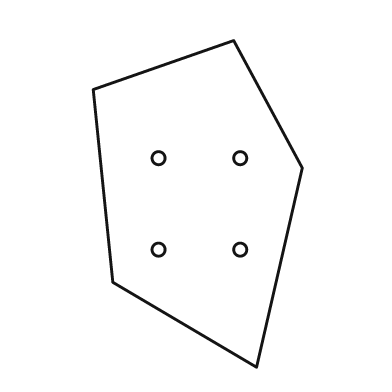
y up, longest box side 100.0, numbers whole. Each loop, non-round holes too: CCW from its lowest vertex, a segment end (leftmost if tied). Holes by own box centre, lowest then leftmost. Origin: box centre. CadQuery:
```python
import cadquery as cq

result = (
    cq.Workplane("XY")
    .moveTo(18.0, -50.0)
    .lineTo(32.0, 11.0)
    .lineTo(11.0, 50.0)
    .lineTo(-32.0, 35.0)
    .lineTo(-26.0, -24.0)
    .close()
    .moveTo(-12.0, -14.0)
    .circle(2.0)
    .moveTo(13.0, -14.0)
    .circle(2.0)
    .moveTo(-12.0, 14.0)
    .circle(2.0)
    .moveTo(13.0, 14.0)
    .circle(2.0)
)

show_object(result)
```